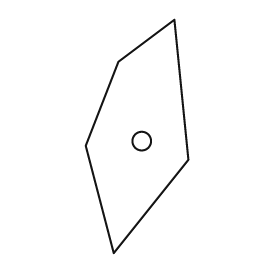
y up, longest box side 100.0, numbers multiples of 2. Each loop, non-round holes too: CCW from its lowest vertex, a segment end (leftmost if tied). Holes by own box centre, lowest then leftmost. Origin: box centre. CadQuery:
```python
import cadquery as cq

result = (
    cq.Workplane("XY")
    .moveTo(-10.0, -50.0)
    .lineTo(22.0, -10.0)
    .lineTo(16.0, 50.0)
    .lineTo(-8.0, 32.0)
    .lineTo(-22.0, -4.0)
    .close()
    .moveTo(2.0, -2.0)
    .circle(4.0)
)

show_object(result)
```